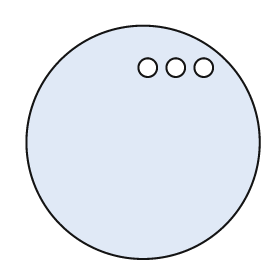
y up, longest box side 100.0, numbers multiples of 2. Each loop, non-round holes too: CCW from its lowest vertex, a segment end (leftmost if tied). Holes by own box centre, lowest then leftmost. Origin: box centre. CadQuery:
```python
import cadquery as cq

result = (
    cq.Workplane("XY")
    .moveTo(0.0, 0.0)
    .circle(50.0)
    .moveTo(2.0, 32.0)
    .circle(4.0)
    .moveTo(14.0, 32.0)
    .circle(4.0)
    .moveTo(26.0, 32.0)
    .circle(4.0)
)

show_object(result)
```